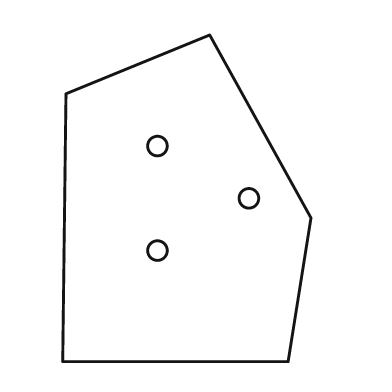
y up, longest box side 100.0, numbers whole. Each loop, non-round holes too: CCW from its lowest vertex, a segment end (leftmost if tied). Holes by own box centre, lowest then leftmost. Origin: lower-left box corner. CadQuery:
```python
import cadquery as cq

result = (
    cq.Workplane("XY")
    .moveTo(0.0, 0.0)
    .lineTo(69.0, 0.0)
    .lineTo(76.0, 44.0)
    .lineTo(45.0, 100.0)
    .lineTo(1.0, 82.0)
    .close()
    .moveTo(29.0, 34.0)
    .circle(3.0)
    .moveTo(57.0, 50.0)
    .circle(3.0)
    .moveTo(29.0, 66.0)
    .circle(3.0)
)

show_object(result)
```